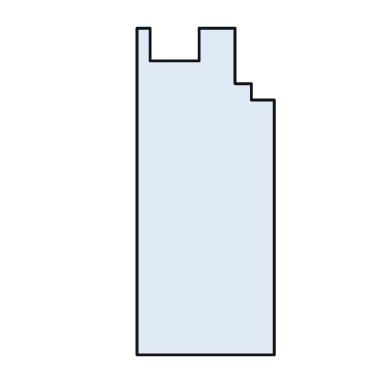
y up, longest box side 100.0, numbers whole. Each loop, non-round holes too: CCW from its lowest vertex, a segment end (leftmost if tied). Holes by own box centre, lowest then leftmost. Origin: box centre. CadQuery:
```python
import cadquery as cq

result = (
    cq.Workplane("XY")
    .moveTo(-21.0, -50.0)
    .lineTo(21.0, -50.0)
    .lineTo(21.0, 28.0)
    .lineTo(14.0, 28.0)
    .lineTo(14.0, 33.0)
    .lineTo(9.0, 33.0)
    .lineTo(9.0, 50.0)
    .lineTo(-2.0, 50.0)
    .lineTo(-2.0, 40.0)
    .lineTo(-17.0, 40.0)
    .lineTo(-17.0, 50.0)
    .lineTo(-21.0, 50.0)
    .close()
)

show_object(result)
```